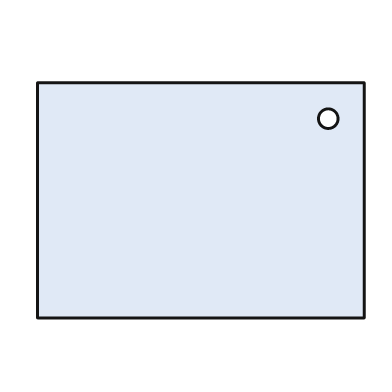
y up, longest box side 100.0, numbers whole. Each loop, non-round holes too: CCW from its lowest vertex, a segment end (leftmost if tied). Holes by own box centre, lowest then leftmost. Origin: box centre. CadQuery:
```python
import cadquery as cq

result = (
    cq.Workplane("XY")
    .moveTo(-50.0, -36.0)
    .lineTo(50.0, -36.0)
    .lineTo(50.0, 36.0)
    .lineTo(-50.0, 36.0)
    .close()
    .moveTo(39.0, 25.0)
    .circle(3.0)
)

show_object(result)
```